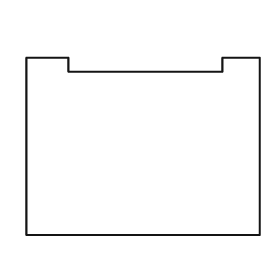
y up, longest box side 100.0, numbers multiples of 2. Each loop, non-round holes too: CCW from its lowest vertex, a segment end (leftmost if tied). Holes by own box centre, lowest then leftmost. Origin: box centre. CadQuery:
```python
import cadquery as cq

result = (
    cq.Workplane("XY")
    .moveTo(-50.0, -38.0)
    .lineTo(50.0, -38.0)
    .lineTo(50.0, 38.0)
    .lineTo(34.0, 38.0)
    .lineTo(34.0, 32.0)
    .lineTo(-32.0, 32.0)
    .lineTo(-32.0, 38.0)
    .lineTo(-50.0, 38.0)
    .close()
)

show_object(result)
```